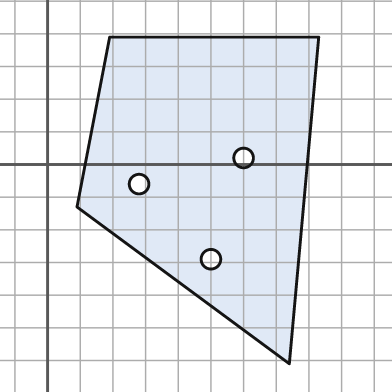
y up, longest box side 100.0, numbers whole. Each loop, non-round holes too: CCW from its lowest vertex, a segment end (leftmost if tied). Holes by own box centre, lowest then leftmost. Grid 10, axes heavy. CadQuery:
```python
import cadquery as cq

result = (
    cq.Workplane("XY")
    .moveTo(74.0, -61.0)
    .lineTo(83.0, 39.0)
    .lineTo(19.0, 39.0)
    .lineTo(9.0, -13.0)
    .close()
    .moveTo(50.0, -29.0)
    .circle(3.0)
    .moveTo(28.0, -6.0)
    .circle(3.0)
    .moveTo(60.0, 2.0)
    .circle(3.0)
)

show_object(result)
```